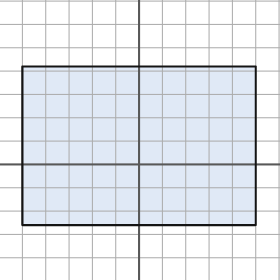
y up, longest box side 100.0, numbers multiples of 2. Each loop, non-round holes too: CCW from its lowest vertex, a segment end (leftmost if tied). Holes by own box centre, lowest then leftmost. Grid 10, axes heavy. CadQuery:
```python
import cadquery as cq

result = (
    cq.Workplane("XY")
    .moveTo(-50.0, -26.0)
    .lineTo(50.0, -26.0)
    .lineTo(50.0, 42.0)
    .lineTo(-50.0, 42.0)
    .close()
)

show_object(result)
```